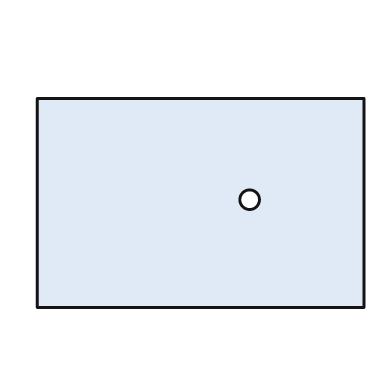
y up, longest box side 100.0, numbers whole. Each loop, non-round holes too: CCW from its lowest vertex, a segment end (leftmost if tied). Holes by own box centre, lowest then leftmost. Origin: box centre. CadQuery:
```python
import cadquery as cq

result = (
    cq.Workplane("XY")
    .moveTo(-50.0, -32.0)
    .lineTo(50.0, -32.0)
    .lineTo(50.0, 32.0)
    .lineTo(-50.0, 32.0)
    .close()
    .moveTo(15.0, 1.0)
    .circle(3.0)
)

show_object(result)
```